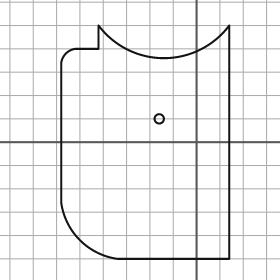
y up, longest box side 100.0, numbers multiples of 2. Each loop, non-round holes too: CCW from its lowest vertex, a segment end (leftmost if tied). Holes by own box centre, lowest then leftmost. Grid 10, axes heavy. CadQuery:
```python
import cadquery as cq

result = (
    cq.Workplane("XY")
    .moveTo(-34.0, -50.0)
    .lineTo(14.0, -50.0)
    .lineTo(14.0, 50.0)
    .threePointArc((-14.0, 36.0), (-42.0, 50.0))
    .lineTo(-42.0, 40.0)
    .lineTo(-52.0, 40.0)
    .threePointArc((-56.0, 38.0), (-58.0, 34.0))
    .lineTo(-58.0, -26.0)
    .threePointArc((-50.0, -42.0), (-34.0, -50.0))
    .close()
    .moveTo(-16.0, 10.0)
    .circle(2.0)
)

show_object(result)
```